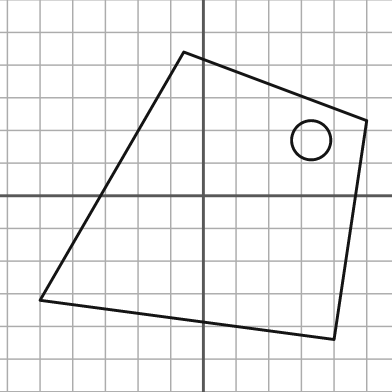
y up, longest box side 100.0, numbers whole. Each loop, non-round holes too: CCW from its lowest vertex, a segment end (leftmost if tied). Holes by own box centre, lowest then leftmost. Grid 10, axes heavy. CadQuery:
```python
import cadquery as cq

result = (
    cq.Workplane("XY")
    .moveTo(40.0, -44.0)
    .lineTo(50.0, 23.0)
    .lineTo(-6.0, 44.0)
    .lineTo(-50.0, -32.0)
    .close()
    .moveTo(33.0, 17.0)
    .circle(6.0)
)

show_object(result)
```